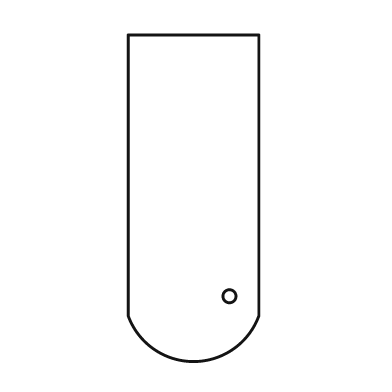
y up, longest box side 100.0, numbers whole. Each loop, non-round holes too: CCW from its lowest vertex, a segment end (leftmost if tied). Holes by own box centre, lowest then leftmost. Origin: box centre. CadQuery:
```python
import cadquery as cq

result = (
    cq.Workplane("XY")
    .moveTo(-20.0, -36.0)
    .threePointArc((0.0, -50.0), (20.0, -36.0))
    .lineTo(20.0, 50.0)
    .lineTo(-20.0, 50.0)
    .close()
    .moveTo(11.0, -30.0)
    .circle(2.0)
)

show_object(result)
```